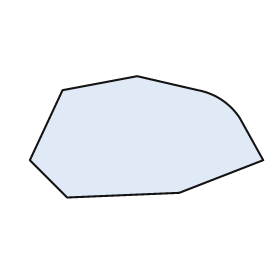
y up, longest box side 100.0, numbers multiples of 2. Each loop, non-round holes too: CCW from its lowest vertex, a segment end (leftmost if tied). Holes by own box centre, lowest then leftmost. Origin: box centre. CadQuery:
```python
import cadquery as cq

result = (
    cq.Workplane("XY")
    .moveTo(-34.0, -26.0)
    .lineTo(14.0, -24.0)
    .lineTo(50.0, -10.0)
    .lineTo(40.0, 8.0)
    .threePointArc((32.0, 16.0), (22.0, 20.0))
    .lineTo(-4.0, 26.0)
    .lineTo(-36.0, 20.0)
    .lineTo(-50.0, -10.0)
    .close()
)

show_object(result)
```